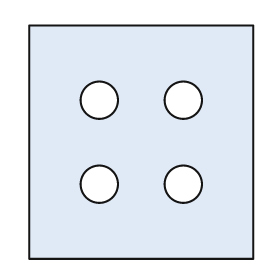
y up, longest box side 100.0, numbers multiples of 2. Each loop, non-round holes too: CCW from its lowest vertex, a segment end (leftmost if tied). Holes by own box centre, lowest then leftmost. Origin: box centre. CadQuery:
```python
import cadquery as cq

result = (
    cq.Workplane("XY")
    .moveTo(-48.0, -50.0)
    .lineTo(48.0, -50.0)
    .lineTo(48.0, 50.0)
    .lineTo(-48.0, 50.0)
    .close()
    .moveTo(-18.0, -18.0)
    .circle(8.0)
    .moveTo(18.0, -18.0)
    .circle(8.0)
    .moveTo(-18.0, 18.0)
    .circle(8.0)
    .moveTo(18.0, 18.0)
    .circle(8.0)
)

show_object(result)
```